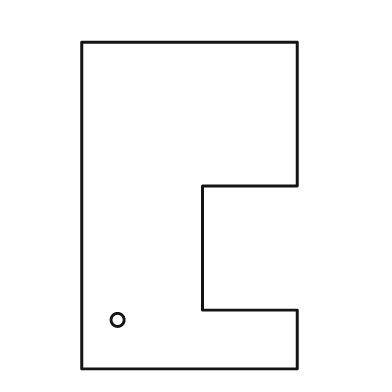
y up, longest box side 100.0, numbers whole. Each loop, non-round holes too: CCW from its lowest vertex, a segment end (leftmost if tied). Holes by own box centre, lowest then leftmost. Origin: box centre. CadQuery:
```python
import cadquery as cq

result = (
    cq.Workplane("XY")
    .moveTo(-33.0, -50.0)
    .lineTo(33.0, -50.0)
    .lineTo(33.0, -32.0)
    .lineTo(4.0, -32.0)
    .lineTo(4.0, 6.0)
    .lineTo(33.0, 6.0)
    .lineTo(33.0, 50.0)
    .lineTo(-33.0, 50.0)
    .close()
    .moveTo(-22.0, -35.0)
    .circle(2.0)
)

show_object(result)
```